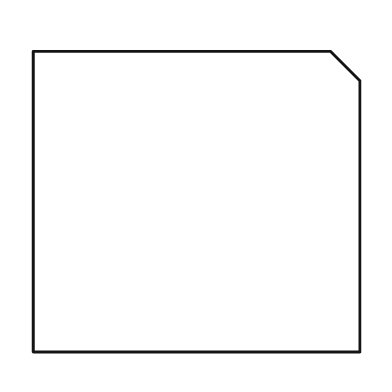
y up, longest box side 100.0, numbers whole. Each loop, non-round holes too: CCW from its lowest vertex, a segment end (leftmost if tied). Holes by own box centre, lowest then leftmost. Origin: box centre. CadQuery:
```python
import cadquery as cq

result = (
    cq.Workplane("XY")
    .moveTo(-50.0, -46.0)
    .lineTo(50.0, -46.0)
    .lineTo(50.0, 37.0)
    .lineTo(41.0, 46.0)
    .lineTo(-50.0, 46.0)
    .close()
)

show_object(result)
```